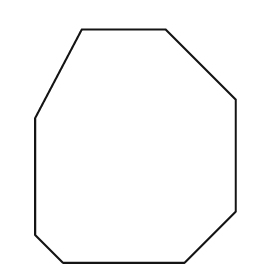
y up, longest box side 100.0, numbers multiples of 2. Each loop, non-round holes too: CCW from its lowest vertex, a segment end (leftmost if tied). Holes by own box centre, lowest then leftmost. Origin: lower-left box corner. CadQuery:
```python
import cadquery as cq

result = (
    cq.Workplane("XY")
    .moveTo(12.0, 0.0)
    .lineTo(64.0, 0.0)
    .lineTo(86.0, 22.0)
    .lineTo(86.0, 70.0)
    .lineTo(56.0, 100.0)
    .lineTo(20.0, 100.0)
    .lineTo(0.0, 62.0)
    .lineTo(0.0, 12.0)
    .close()
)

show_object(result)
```